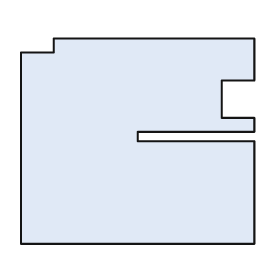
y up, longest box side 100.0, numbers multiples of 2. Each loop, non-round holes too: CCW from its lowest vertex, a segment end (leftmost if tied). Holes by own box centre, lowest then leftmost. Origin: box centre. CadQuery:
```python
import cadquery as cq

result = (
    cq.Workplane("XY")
    .moveTo(-50.0, -44.0)
    .lineTo(50.0, -44.0)
    .lineTo(50.0, 0.0)
    .lineTo(0.0, 0.0)
    .lineTo(0.0, 4.0)
    .lineTo(50.0, 4.0)
    .lineTo(50.0, 10.0)
    .lineTo(36.0, 10.0)
    .lineTo(36.0, 26.0)
    .lineTo(50.0, 26.0)
    .lineTo(50.0, 44.0)
    .lineTo(-36.0, 44.0)
    .lineTo(-36.0, 38.0)
    .lineTo(-50.0, 38.0)
    .close()
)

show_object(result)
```